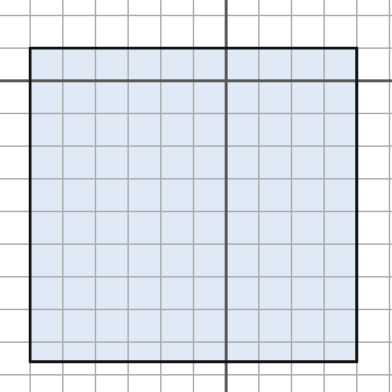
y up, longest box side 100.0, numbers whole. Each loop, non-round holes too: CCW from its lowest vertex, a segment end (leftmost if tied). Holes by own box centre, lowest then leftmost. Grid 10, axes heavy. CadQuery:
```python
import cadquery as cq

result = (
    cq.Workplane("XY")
    .moveTo(-60.0, -86.0)
    .lineTo(40.0, -86.0)
    .lineTo(40.0, 10.0)
    .lineTo(-60.0, 10.0)
    .close()
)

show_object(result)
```